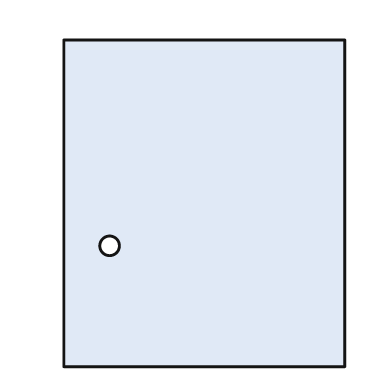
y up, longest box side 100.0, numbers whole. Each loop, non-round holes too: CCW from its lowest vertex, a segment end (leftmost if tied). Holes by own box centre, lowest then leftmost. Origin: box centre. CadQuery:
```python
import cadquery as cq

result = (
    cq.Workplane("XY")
    .moveTo(-43.0, -50.0)
    .lineTo(43.0, -50.0)
    .lineTo(43.0, 50.0)
    .lineTo(-43.0, 50.0)
    .close()
    .moveTo(-29.0, -13.0)
    .circle(3.0)
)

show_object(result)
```